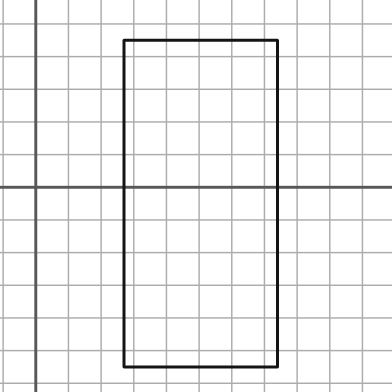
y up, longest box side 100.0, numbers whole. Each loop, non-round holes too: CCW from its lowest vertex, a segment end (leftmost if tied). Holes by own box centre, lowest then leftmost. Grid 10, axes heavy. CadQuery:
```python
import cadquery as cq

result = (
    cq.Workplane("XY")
    .moveTo(27.0, -55.0)
    .lineTo(74.0, -55.0)
    .lineTo(74.0, 45.0)
    .lineTo(27.0, 45.0)
    .close()
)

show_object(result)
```